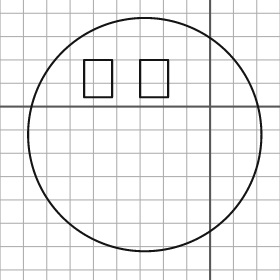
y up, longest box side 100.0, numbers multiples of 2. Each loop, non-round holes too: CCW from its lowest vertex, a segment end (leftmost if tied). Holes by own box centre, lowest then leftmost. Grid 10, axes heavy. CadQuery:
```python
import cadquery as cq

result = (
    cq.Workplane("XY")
    .moveTo(-28.0, -12.0)
    .circle(50.0)
    .moveTo(-54.0, 4.0)
    .lineTo(-42.0, 4.0)
    .lineTo(-42.0, 20.0)
    .lineTo(-54.0, 20.0)
    .close()
    .moveTo(-30.0, 4.0)
    .lineTo(-18.0, 4.0)
    .lineTo(-18.0, 20.0)
    .lineTo(-30.0, 20.0)
    .close()
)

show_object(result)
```